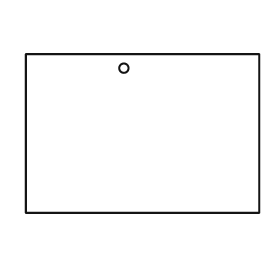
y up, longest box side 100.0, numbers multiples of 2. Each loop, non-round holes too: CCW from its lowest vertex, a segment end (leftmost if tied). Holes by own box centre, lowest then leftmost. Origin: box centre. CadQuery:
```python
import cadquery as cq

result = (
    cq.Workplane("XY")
    .moveTo(-50.0, -34.0)
    .lineTo(50.0, -34.0)
    .lineTo(50.0, 34.0)
    .lineTo(-50.0, 34.0)
    .close()
    .moveTo(-8.0, 28.0)
    .circle(2.0)
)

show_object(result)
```